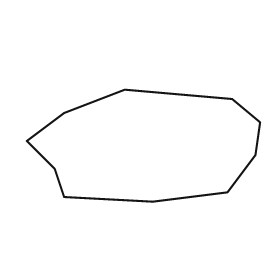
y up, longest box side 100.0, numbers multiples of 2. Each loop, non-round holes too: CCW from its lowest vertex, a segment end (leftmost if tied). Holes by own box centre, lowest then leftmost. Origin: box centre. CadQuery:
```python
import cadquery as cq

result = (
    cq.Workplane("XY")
    .moveTo(4.0, -24.0)
    .lineTo(36.0, -20.0)
    .lineTo(48.0, -4.0)
    .lineTo(50.0, 10.0)
    .lineTo(38.0, 20.0)
    .lineTo(-8.0, 24.0)
    .lineTo(-34.0, 14.0)
    .lineTo(-50.0, 2.0)
    .lineTo(-38.0, -10.0)
    .lineTo(-34.0, -22.0)
    .close()
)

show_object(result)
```